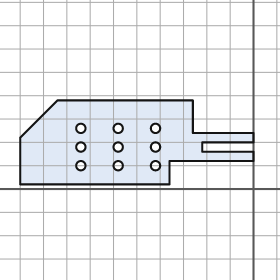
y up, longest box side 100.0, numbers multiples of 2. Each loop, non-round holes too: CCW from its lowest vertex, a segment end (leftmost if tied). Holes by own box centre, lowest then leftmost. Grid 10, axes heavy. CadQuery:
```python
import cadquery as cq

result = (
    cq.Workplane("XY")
    .moveTo(-100.0, 2.0)
    .lineTo(-36.0, 2.0)
    .lineTo(-36.0, 12.0)
    .lineTo(0.0, 12.0)
    .lineTo(0.0, 16.0)
    .lineTo(-22.0, 16.0)
    .lineTo(-22.0, 20.0)
    .lineTo(0.0, 20.0)
    .lineTo(0.0, 24.0)
    .lineTo(-26.0, 24.0)
    .lineTo(-26.0, 38.0)
    .lineTo(-84.0, 38.0)
    .lineTo(-100.0, 22.0)
    .close()
    .moveTo(-74.0, 10.0)
    .circle(2.0)
    .moveTo(-58.0, 10.0)
    .circle(2.0)
    .moveTo(-42.0, 10.0)
    .circle(2.0)
    .moveTo(-74.0, 18.0)
    .circle(2.0)
    .moveTo(-58.0, 18.0)
    .circle(2.0)
    .moveTo(-42.0, 18.0)
    .circle(2.0)
    .moveTo(-74.0, 26.0)
    .circle(2.0)
    .moveTo(-58.0, 26.0)
    .circle(2.0)
    .moveTo(-42.0, 26.0)
    .circle(2.0)
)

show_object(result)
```